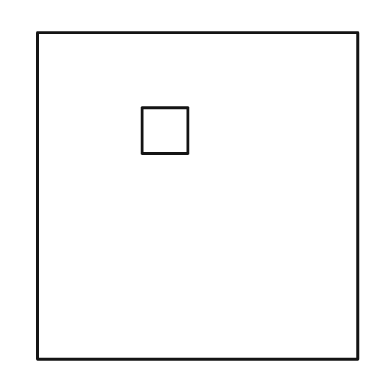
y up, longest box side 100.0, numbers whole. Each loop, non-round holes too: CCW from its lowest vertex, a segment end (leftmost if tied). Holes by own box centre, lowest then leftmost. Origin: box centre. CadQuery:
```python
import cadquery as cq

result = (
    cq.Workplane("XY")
    .moveTo(-49.0, -50.0)
    .lineTo(49.0, -50.0)
    .lineTo(49.0, 50.0)
    .lineTo(-49.0, 50.0)
    .close()
    .moveTo(-17.0, 13.0)
    .lineTo(-3.0, 13.0)
    .lineTo(-3.0, 27.0)
    .lineTo(-17.0, 27.0)
    .close()
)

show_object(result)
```